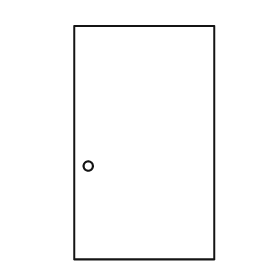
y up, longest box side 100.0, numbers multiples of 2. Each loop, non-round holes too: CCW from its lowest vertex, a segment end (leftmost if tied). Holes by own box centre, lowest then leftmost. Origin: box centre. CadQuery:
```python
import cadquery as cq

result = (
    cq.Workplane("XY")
    .moveTo(-30.0, -50.0)
    .lineTo(30.0, -50.0)
    .lineTo(30.0, 50.0)
    .lineTo(-30.0, 50.0)
    .close()
    .moveTo(-24.0, -10.0)
    .circle(2.0)
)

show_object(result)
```